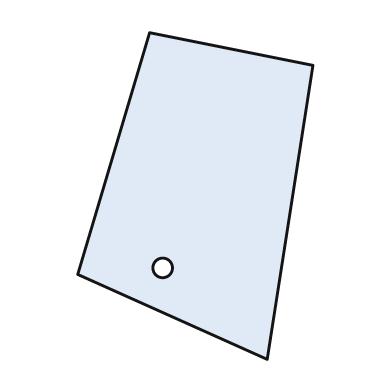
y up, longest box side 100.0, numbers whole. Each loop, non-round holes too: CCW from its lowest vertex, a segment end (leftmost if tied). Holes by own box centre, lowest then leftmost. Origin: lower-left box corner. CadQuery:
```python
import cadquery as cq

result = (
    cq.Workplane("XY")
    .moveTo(58.0, 0.0)
    .lineTo(72.0, 90.0)
    .lineTo(22.0, 100.0)
    .lineTo(0.0, 26.0)
    .close()
    .moveTo(26.0, 28.0)
    .circle(3.0)
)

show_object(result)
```